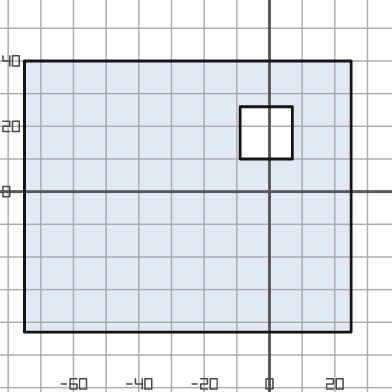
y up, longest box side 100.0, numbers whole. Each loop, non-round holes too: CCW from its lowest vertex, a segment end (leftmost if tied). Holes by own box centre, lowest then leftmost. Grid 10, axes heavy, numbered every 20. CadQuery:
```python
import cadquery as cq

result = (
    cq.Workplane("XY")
    .moveTo(-75.0, -43.0)
    .lineTo(25.0, -43.0)
    .lineTo(25.0, 40.0)
    .lineTo(-75.0, 40.0)
    .close()
    .moveTo(-9.0, 10.0)
    .lineTo(7.0, 10.0)
    .lineTo(7.0, 26.0)
    .lineTo(-9.0, 26.0)
    .close()
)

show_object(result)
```